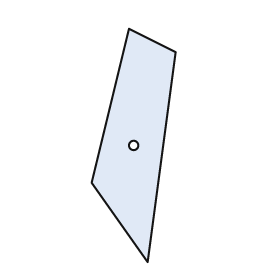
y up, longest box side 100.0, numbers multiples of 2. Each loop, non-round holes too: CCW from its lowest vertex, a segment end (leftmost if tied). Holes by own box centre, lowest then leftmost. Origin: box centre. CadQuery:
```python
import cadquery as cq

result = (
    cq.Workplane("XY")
    .moveTo(6.0, -50.0)
    .lineTo(18.0, 40.0)
    .lineTo(-2.0, 50.0)
    .lineTo(-18.0, -16.0)
    .close()
    .moveTo(0.0, 0.0)
    .circle(2.0)
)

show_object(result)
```